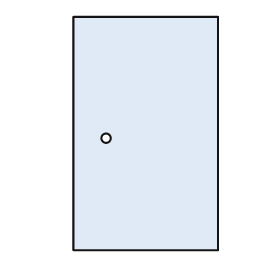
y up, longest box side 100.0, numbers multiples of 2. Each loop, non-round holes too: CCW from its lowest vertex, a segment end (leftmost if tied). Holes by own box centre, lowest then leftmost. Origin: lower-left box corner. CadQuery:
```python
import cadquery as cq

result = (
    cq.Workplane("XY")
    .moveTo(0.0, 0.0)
    .lineTo(62.0, 0.0)
    .lineTo(62.0, 100.0)
    .lineTo(0.0, 100.0)
    .close()
    .moveTo(14.0, 48.0)
    .circle(2.0)
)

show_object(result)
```